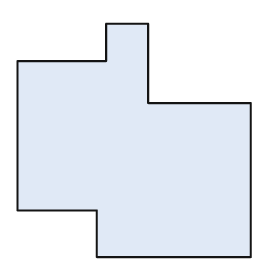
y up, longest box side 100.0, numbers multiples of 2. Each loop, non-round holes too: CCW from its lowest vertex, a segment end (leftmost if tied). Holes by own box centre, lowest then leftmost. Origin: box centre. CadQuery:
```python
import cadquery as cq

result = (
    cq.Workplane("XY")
    .moveTo(-16.0, -50.0)
    .lineTo(50.0, -50.0)
    .lineTo(50.0, 16.0)
    .lineTo(6.0, 16.0)
    .lineTo(6.0, 50.0)
    .lineTo(-12.0, 50.0)
    .lineTo(-12.0, 34.0)
    .lineTo(-50.0, 34.0)
    .lineTo(-50.0, -30.0)
    .lineTo(-16.0, -30.0)
    .close()
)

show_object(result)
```